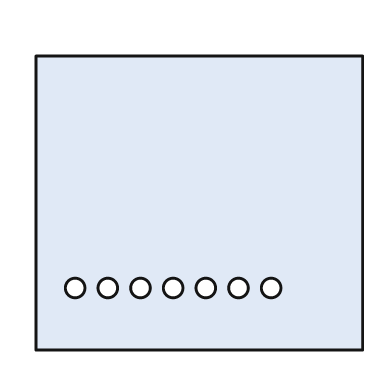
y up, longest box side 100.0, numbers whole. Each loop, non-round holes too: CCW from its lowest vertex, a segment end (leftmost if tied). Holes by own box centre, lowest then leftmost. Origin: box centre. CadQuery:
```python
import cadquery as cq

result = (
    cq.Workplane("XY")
    .moveTo(-50.0, -45.0)
    .lineTo(50.0, -45.0)
    .lineTo(50.0, 45.0)
    .lineTo(-50.0, 45.0)
    .close()
    .moveTo(-38.0, -26.0)
    .circle(3.0)
    .moveTo(-28.0, -26.0)
    .circle(3.0)
    .moveTo(-18.0, -26.0)
    .circle(3.0)
    .moveTo(-8.0, -26.0)
    .circle(3.0)
    .moveTo(2.0, -26.0)
    .circle(3.0)
    .moveTo(12.0, -26.0)
    .circle(3.0)
    .moveTo(22.0, -26.0)
    .circle(3.0)
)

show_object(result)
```